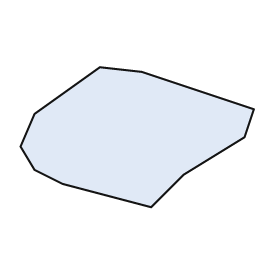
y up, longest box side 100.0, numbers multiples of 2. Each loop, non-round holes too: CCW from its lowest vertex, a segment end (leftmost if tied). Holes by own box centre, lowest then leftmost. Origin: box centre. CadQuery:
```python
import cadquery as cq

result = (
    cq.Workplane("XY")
    .moveTo(6.0, -30.0)
    .lineTo(20.0, -16.0)
    .lineTo(46.0, 0.0)
    .lineTo(50.0, 12.0)
    .lineTo(2.0, 28.0)
    .lineTo(-16.0, 30.0)
    .lineTo(-44.0, 10.0)
    .lineTo(-50.0, -4.0)
    .lineTo(-44.0, -14.0)
    .lineTo(-32.0, -20.0)
    .close()
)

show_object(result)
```